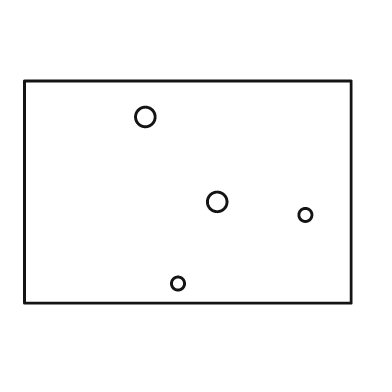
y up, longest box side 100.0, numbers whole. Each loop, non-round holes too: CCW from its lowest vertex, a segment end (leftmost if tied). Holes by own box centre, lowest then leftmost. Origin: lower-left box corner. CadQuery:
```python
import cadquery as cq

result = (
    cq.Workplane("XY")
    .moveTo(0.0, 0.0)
    .lineTo(100.0, 0.0)
    .lineTo(100.0, 68.0)
    .lineTo(0.0, 68.0)
    .close()
    .moveTo(47.0, 6.0)
    .circle(2.0)
    .moveTo(86.0, 27.0)
    .circle(2.0)
    .moveTo(59.0, 31.0)
    .circle(3.0)
    .moveTo(37.0, 57.0)
    .circle(3.0)
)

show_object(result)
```